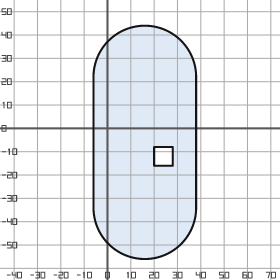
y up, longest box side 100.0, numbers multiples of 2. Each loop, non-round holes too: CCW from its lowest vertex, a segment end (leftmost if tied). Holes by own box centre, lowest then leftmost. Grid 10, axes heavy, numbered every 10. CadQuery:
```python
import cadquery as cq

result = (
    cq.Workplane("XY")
    .moveTo(-6.0, -34.0)
    .threePointArc((16.0, -56.0), (38.0, -34.0))
    .lineTo(38.0, 22.0)
    .threePointArc((16.0, 44.0), (-6.0, 22.0))
    .close()
    .moveTo(20.0, -16.0)
    .lineTo(28.0, -16.0)
    .lineTo(28.0, -8.0)
    .lineTo(20.0, -8.0)
    .close()
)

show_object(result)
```